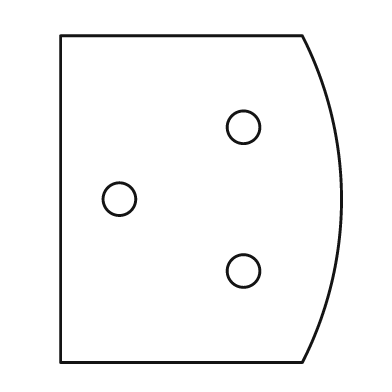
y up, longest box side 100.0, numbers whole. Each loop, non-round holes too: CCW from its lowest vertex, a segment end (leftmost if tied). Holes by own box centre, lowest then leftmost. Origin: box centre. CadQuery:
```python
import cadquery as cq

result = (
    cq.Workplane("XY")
    .moveTo(-43.0, -50.0)
    .lineTo(31.0, -50.0)
    .threePointArc((43.0, 0.0), (31.0, 50.0))
    .lineTo(-43.0, 50.0)
    .close()
    .moveTo(13.0, -22.0)
    .circle(5.0)
    .moveTo(-25.0, 0.0)
    .circle(5.0)
    .moveTo(13.0, 22.0)
    .circle(5.0)
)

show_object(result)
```